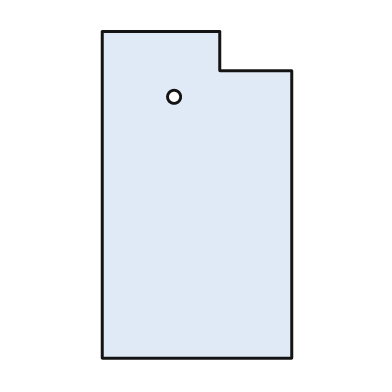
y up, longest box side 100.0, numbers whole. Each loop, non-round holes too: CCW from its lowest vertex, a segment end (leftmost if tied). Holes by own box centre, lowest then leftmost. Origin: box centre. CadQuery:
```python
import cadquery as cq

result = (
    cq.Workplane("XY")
    .moveTo(-29.0, -50.0)
    .lineTo(29.0, -50.0)
    .lineTo(29.0, 38.0)
    .lineTo(7.0, 38.0)
    .lineTo(7.0, 50.0)
    .lineTo(-29.0, 50.0)
    .close()
    .moveTo(-7.0, 30.0)
    .circle(2.0)
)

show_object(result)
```